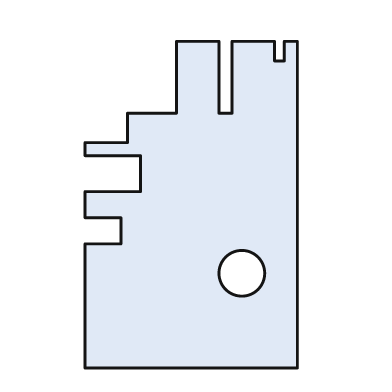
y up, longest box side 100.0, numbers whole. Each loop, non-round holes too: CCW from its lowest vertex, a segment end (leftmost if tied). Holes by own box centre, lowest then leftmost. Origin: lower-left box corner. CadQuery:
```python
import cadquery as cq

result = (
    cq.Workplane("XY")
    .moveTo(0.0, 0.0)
    .lineTo(65.0, 0.0)
    .lineTo(65.0, 100.0)
    .lineTo(61.0, 100.0)
    .lineTo(61.0, 94.0)
    .lineTo(58.0, 94.0)
    .lineTo(58.0, 100.0)
    .lineTo(45.0, 100.0)
    .lineTo(45.0, 78.0)
    .lineTo(41.0, 78.0)
    .lineTo(41.0, 100.0)
    .lineTo(28.0, 100.0)
    .lineTo(28.0, 78.0)
    .lineTo(13.0, 78.0)
    .lineTo(13.0, 69.0)
    .lineTo(0.0, 69.0)
    .lineTo(0.0, 65.0)
    .lineTo(17.0, 65.0)
    .lineTo(17.0, 54.0)
    .lineTo(0.0, 54.0)
    .lineTo(0.0, 46.0)
    .lineTo(11.0, 46.0)
    .lineTo(11.0, 38.0)
    .lineTo(0.0, 38.0)
    .close()
    .moveTo(48.0, 29.0)
    .circle(7.0)
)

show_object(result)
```